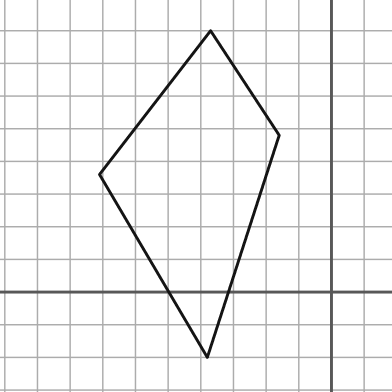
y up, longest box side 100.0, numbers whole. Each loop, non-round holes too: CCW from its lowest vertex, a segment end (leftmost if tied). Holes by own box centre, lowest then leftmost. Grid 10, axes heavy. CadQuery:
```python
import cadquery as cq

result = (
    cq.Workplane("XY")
    .moveTo(-38.0, -20.0)
    .lineTo(-16.0, 48.0)
    .lineTo(-37.0, 80.0)
    .lineTo(-71.0, 36.0)
    .close()
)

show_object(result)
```